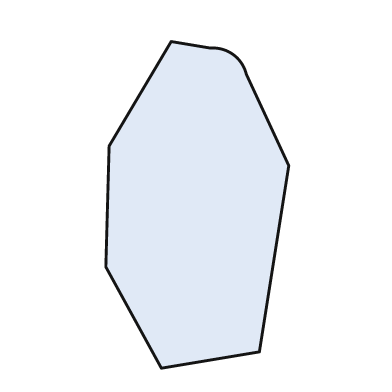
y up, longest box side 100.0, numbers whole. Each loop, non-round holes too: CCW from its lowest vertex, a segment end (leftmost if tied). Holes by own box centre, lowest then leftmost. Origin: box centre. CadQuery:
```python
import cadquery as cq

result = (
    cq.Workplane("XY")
    .moveTo(-11.0, -50.0)
    .lineTo(19.0, -45.0)
    .lineTo(28.0, 12.0)
    .lineTo(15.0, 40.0)
    .threePointArc((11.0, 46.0), (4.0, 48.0))
    .lineTo(-8.0, 50.0)
    .lineTo(-27.0, 18.0)
    .lineTo(-28.0, -19.0)
    .close()
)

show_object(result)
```